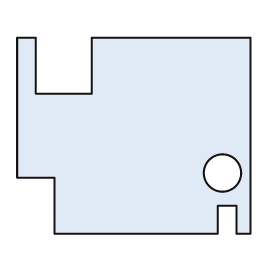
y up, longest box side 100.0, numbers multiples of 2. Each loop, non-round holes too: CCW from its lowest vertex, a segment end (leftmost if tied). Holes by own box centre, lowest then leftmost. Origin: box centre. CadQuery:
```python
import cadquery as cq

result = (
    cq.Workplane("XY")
    .moveTo(-34.0, -42.0)
    .lineTo(36.0, -42.0)
    .lineTo(36.0, -30.0)
    .lineTo(44.0, -30.0)
    .lineTo(44.0, -42.0)
    .lineTo(50.0, -42.0)
    .lineTo(50.0, 42.0)
    .lineTo(-18.0, 42.0)
    .lineTo(-18.0, 18.0)
    .lineTo(-42.0, 18.0)
    .lineTo(-42.0, 42.0)
    .lineTo(-50.0, 42.0)
    .lineTo(-50.0, -18.0)
    .lineTo(-34.0, -18.0)
    .close()
    .moveTo(38.0, -16.0)
    .circle(8.0)
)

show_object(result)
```